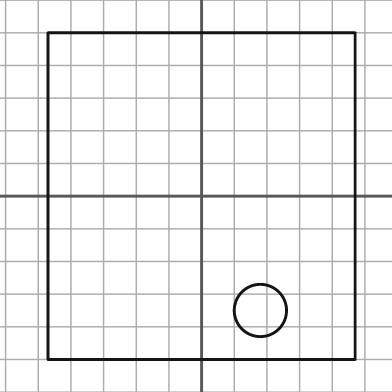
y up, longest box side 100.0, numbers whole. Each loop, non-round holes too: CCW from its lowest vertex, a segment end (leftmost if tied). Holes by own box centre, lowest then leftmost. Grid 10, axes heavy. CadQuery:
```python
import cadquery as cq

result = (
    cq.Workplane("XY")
    .moveTo(-47.0, -50.0)
    .lineTo(47.0, -50.0)
    .lineTo(47.0, 50.0)
    .lineTo(-47.0, 50.0)
    .close()
    .moveTo(18.0, -35.0)
    .circle(8.0)
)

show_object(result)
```